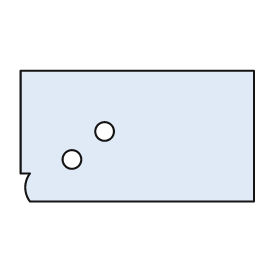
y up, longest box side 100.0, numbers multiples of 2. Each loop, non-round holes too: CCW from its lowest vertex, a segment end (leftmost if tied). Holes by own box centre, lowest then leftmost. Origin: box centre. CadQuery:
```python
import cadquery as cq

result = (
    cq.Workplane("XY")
    .moveTo(-46.0, -28.0)
    .lineTo(50.0, -28.0)
    .lineTo(50.0, 28.0)
    .lineTo(-50.0, 28.0)
    .lineTo(-50.0, -16.0)
    .lineTo(-46.0, -16.0)
    .threePointArc((-48.0, -22.0), (-46.0, -28.0))
    .close()
    .moveTo(-28.0, -10.0)
    .circle(4.0)
    .moveTo(-14.0, 2.0)
    .circle(4.0)
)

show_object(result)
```